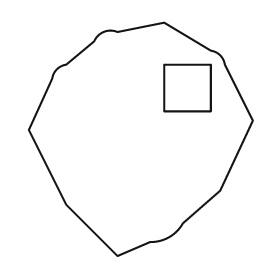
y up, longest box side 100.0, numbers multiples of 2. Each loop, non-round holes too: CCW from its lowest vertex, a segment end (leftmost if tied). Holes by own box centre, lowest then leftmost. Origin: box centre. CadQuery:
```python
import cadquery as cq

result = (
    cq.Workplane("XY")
    .moveTo(-10.0, -50.0)
    .lineTo(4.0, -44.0)
    .threePointArc((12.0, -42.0), (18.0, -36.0))
    .lineTo(34.0, -22.0)
    .lineTo(48.0, 8.0)
    .lineTo(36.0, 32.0)
    .threePointArc((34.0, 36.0), (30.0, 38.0))
    .lineTo(10.0, 50.0)
    .lineTo(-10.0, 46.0)
    .threePointArc((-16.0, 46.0), (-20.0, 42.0))
    .lineTo(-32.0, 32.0)
    .threePointArc((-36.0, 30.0), (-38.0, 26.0))
    .lineTo(-48.0, 4.0)
    .lineTo(-32.0, -28.0)
    .close()
    .moveTo(10.0, 12.0)
    .lineTo(30.0, 12.0)
    .lineTo(30.0, 32.0)
    .lineTo(10.0, 32.0)
    .close()
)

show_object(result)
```